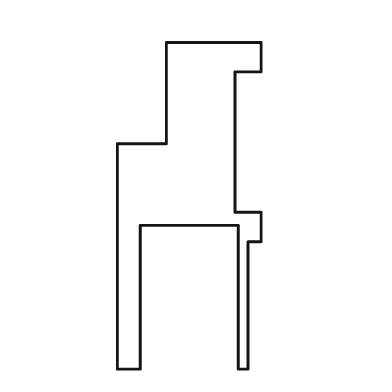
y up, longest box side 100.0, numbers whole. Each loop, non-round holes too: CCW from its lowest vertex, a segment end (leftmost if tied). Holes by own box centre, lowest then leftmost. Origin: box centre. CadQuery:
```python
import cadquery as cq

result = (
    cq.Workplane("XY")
    .moveTo(-22.0, -50.0)
    .lineTo(-15.0, -50.0)
    .lineTo(-15.0, -6.0)
    .lineTo(15.0, -6.0)
    .lineTo(15.0, -50.0)
    .lineTo(18.0, -50.0)
    .lineTo(18.0, -11.0)
    .lineTo(22.0, -11.0)
    .lineTo(22.0, -2.0)
    .lineTo(14.0, -2.0)
    .lineTo(14.0, 41.0)
    .lineTo(22.0, 41.0)
    .lineTo(22.0, 50.0)
    .lineTo(-7.0, 50.0)
    .lineTo(-7.0, 19.0)
    .lineTo(-22.0, 19.0)
    .close()
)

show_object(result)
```